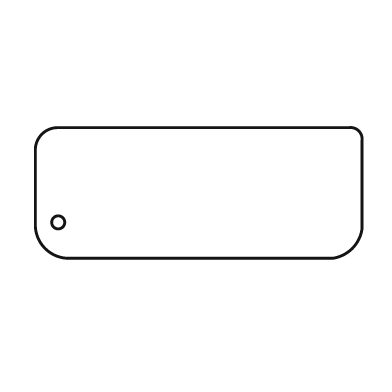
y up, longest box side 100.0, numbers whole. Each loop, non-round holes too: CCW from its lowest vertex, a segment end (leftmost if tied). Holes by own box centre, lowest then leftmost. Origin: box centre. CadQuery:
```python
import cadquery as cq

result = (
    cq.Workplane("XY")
    .moveTo(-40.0, -20.0)
    .lineTo(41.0, -20.0)
    .threePointArc((47.0, -17.0), (50.0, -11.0))
    .lineTo(50.0, 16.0)
    .threePointArc((49.0, 19.0), (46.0, 20.0))
    .lineTo(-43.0, 20.0)
    .threePointArc((-48.0, 18.0), (-50.0, 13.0))
    .lineTo(-50.0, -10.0)
    .threePointArc((-47.0, -17.0), (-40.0, -20.0))
    .close()
    .moveTo(-43.0, -9.0)
    .circle(2.0)
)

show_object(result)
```